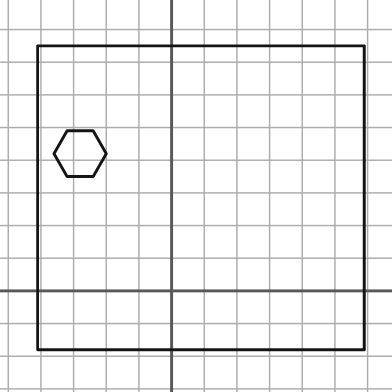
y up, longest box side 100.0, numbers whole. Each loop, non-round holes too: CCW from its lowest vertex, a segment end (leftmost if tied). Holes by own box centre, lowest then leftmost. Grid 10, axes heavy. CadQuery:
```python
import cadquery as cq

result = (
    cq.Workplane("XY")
    .moveTo(-41.0, -18.0)
    .lineTo(59.0, -18.0)
    .lineTo(59.0, 75.0)
    .lineTo(-41.0, 75.0)
    .close()
    .moveTo(-32.0, 35.0)
    .lineTo(-24.0, 35.0)
    .lineTo(-20.0, 42.0)
    .lineTo(-24.0, 49.0)
    .lineTo(-32.0, 49.0)
    .lineTo(-36.0, 42.0)
    .close()
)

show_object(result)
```